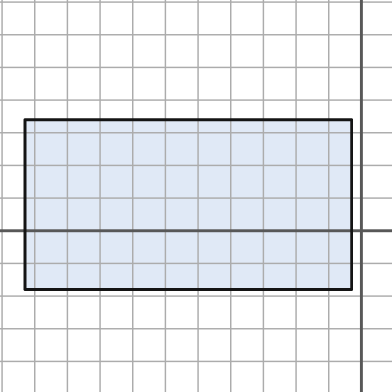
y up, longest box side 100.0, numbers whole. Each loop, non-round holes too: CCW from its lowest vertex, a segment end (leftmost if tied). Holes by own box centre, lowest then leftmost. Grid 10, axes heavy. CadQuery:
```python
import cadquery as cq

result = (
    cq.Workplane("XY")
    .moveTo(-103.0, -18.0)
    .lineTo(-3.0, -18.0)
    .lineTo(-3.0, 34.0)
    .lineTo(-103.0, 34.0)
    .close()
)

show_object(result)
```